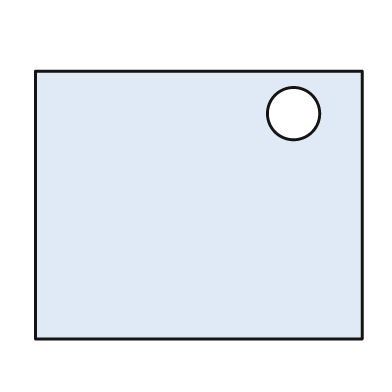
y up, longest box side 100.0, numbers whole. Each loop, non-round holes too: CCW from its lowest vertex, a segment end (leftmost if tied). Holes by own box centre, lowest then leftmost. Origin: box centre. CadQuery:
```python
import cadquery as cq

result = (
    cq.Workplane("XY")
    .moveTo(-50.0, -41.0)
    .lineTo(50.0, -41.0)
    .lineTo(50.0, 41.0)
    .lineTo(-50.0, 41.0)
    .close()
    .moveTo(29.0, 28.0)
    .circle(8.0)
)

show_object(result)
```